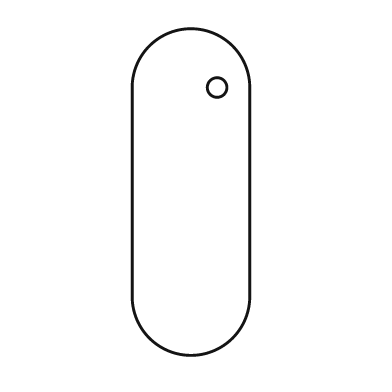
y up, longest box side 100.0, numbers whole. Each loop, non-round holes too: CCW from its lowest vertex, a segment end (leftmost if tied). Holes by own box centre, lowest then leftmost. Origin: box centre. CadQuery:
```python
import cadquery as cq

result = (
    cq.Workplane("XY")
    .moveTo(-18.0, -32.0)
    .threePointArc((0.0, -50.0), (18.0, -32.0))
    .lineTo(18.0, 32.0)
    .threePointArc((0.0, 50.0), (-18.0, 32.0))
    .close()
    .moveTo(8.0, 32.0)
    .circle(3.0)
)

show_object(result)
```